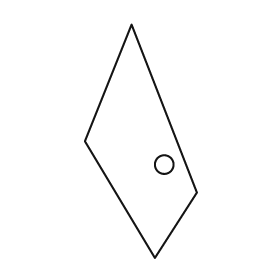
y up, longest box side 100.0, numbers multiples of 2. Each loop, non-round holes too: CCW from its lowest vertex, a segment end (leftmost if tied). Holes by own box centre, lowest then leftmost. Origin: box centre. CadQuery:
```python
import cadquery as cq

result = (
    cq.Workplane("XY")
    .moveTo(6.0, -50.0)
    .lineTo(24.0, -22.0)
    .lineTo(-4.0, 50.0)
    .lineTo(-24.0, 0.0)
    .close()
    .moveTo(10.0, -10.0)
    .circle(4.0)
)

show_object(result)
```